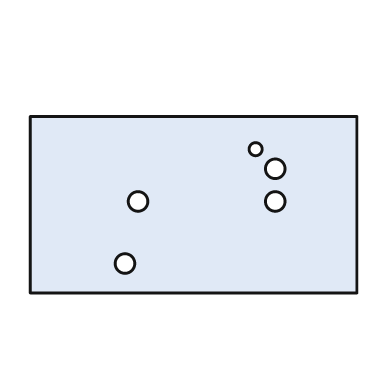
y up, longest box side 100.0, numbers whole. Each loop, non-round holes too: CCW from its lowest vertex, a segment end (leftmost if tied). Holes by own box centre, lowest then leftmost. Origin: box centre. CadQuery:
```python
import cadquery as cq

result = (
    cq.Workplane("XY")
    .moveTo(-50.0, -27.0)
    .lineTo(50.0, -27.0)
    .lineTo(50.0, 27.0)
    .lineTo(-50.0, 27.0)
    .close()
    .moveTo(-21.0, -18.0)
    .circle(3.0)
    .moveTo(-17.0, 1.0)
    .circle(3.0)
    .moveTo(25.0, 1.0)
    .circle(3.0)
    .moveTo(25.0, 11.0)
    .circle(3.0)
    .moveTo(19.0, 17.0)
    .circle(2.0)
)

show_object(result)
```